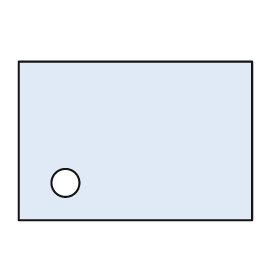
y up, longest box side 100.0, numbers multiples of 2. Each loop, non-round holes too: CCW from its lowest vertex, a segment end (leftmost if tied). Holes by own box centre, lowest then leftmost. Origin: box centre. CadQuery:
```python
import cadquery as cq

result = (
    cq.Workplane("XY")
    .moveTo(-50.0, -34.0)
    .lineTo(50.0, -34.0)
    .lineTo(50.0, 34.0)
    .lineTo(-50.0, 34.0)
    .close()
    .moveTo(-30.0, -18.0)
    .circle(6.0)
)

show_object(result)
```